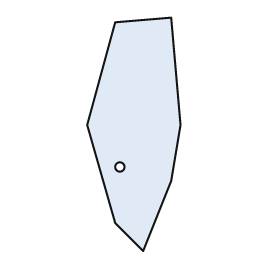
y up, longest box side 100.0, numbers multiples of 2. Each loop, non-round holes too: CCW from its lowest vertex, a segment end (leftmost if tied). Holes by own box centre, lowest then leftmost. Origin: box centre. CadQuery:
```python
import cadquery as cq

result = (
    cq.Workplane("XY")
    .moveTo(4.0, -50.0)
    .lineTo(16.0, -20.0)
    .lineTo(20.0, 4.0)
    .lineTo(16.0, 50.0)
    .lineTo(-8.0, 48.0)
    .lineTo(-20.0, 4.0)
    .lineTo(-8.0, -38.0)
    .close()
    .moveTo(-6.0, -14.0)
    .circle(2.0)
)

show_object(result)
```